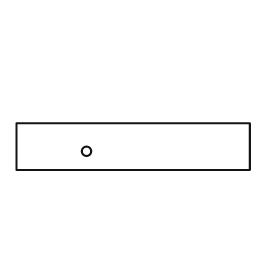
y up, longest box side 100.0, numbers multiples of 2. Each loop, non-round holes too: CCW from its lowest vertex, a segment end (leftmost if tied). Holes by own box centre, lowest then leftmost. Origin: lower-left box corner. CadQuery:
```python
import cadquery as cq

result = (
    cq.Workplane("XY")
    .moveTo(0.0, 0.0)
    .lineTo(100.0, 0.0)
    .lineTo(100.0, 20.0)
    .lineTo(0.0, 20.0)
    .close()
    .moveTo(30.0, 8.0)
    .circle(2.0)
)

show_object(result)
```